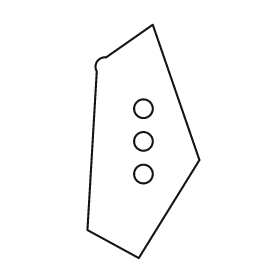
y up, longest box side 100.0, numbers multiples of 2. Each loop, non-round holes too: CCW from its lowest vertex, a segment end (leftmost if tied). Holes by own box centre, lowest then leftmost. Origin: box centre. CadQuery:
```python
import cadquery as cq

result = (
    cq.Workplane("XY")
    .moveTo(-2.0, -50.0)
    .lineTo(24.0, -8.0)
    .lineTo(4.0, 50.0)
    .lineTo(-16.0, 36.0)
    .threePointArc((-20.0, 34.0), (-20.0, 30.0))
    .lineTo(-24.0, -38.0)
    .close()
    .moveTo(0.0, -14.0)
    .circle(4.0)
    .moveTo(0.0, 0.0)
    .circle(4.0)
    .moveTo(0.0, 14.0)
    .circle(4.0)
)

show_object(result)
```